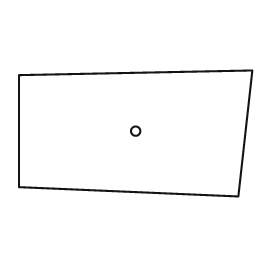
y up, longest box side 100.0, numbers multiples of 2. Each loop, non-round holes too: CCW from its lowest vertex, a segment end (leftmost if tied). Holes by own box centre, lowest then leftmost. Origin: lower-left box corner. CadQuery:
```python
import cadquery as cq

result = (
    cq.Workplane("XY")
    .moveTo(94.0, 0.0)
    .lineTo(100.0, 54.0)
    .lineTo(0.0, 52.0)
    .lineTo(0.0, 4.0)
    .close()
    .moveTo(50.0, 28.0)
    .circle(2.0)
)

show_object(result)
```